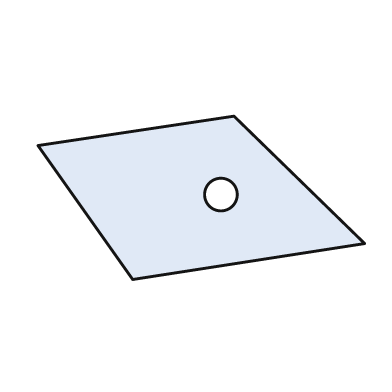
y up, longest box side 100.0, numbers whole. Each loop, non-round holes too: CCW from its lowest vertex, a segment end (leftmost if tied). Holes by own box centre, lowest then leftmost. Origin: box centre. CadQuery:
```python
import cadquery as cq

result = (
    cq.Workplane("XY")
    .moveTo(-21.0, -25.0)
    .lineTo(50.0, -14.0)
    .lineTo(10.0, 25.0)
    .lineTo(-50.0, 16.0)
    .close()
    .moveTo(6.0, 1.0)
    .circle(5.0)
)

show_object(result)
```